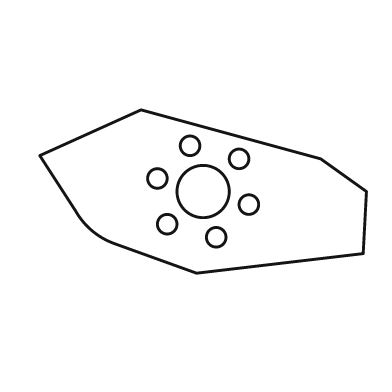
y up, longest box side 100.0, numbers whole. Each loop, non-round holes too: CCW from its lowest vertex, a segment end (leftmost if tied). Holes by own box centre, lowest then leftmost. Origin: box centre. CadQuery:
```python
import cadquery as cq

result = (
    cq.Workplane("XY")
    .moveTo(-2.0, -25.0)
    .lineTo(49.0, -19.0)
    .lineTo(50.0, 0.0)
    .lineTo(36.0, 10.0)
    .lineTo(-19.0, 25.0)
    .lineTo(-50.0, 11.0)
    .lineTo(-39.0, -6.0)
    .threePointArc((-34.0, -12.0), (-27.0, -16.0))
    .close()
    .moveTo(4.0, -14.0)
    .circle(3.0)
    .moveTo(-11.0, -10.0)
    .circle(3.0)
    .moveTo(14.0, -4.0)
    .circle(3.0)
    .moveTo(0.0, 0.0)
    .circle(8.0)
    .moveTo(-14.0, 4.0)
    .circle(3.0)
    .moveTo(11.0, 10.0)
    .circle(3.0)
    .moveTo(-4.0, 14.0)
    .circle(3.0)
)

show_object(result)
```